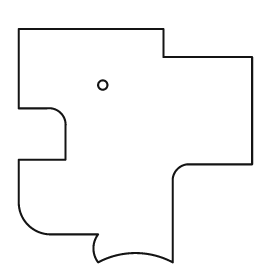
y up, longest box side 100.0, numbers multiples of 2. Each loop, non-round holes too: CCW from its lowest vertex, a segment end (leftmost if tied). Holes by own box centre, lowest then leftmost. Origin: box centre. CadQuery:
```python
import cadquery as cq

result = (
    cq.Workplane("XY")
    .moveTo(-16.0, -50.0)
    .threePointArc((0.0, -46.0), (16.0, -50.0))
    .lineTo(16.0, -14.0)
    .threePointArc((18.0, -10.0), (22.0, -8.0))
    .lineTo(50.0, -8.0)
    .lineTo(50.0, 38.0)
    .lineTo(12.0, 38.0)
    .lineTo(12.0, 50.0)
    .lineTo(-50.0, 50.0)
    .lineTo(-50.0, 16.0)
    .lineTo(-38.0, 16.0)
    .threePointArc((-32.0, 14.0), (-30.0, 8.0))
    .lineTo(-30.0, -6.0)
    .lineTo(-50.0, -6.0)
    .lineTo(-50.0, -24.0)
    .threePointArc((-46.0, -34.0), (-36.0, -38.0))
    .lineTo(-16.0, -38.0)
    .threePointArc((-18.0, -44.0), (-16.0, -50.0))
    .close()
    .moveTo(-14.0, 26.0)
    .circle(2.0)
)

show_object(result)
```